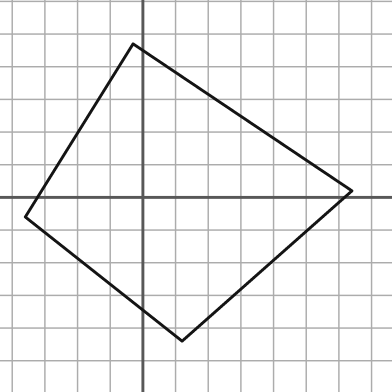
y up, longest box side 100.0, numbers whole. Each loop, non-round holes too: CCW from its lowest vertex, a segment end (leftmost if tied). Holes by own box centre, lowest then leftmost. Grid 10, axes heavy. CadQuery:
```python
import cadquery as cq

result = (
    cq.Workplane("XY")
    .moveTo(12.0, -44.0)
    .lineTo(64.0, 2.0)
    .lineTo(-3.0, 47.0)
    .lineTo(-36.0, -6.0)
    .close()
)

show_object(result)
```